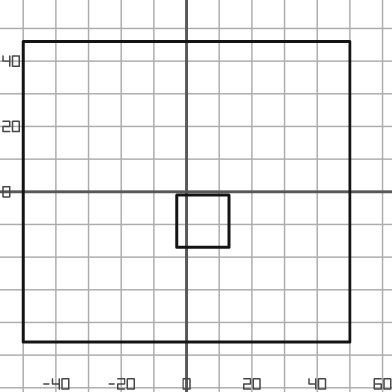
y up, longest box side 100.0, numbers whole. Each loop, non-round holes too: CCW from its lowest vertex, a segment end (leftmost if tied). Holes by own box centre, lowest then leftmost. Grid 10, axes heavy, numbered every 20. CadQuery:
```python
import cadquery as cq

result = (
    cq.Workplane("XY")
    .moveTo(-50.0, -46.0)
    .lineTo(50.0, -46.0)
    .lineTo(50.0, 46.0)
    .lineTo(-50.0, 46.0)
    .close()
    .moveTo(-3.0, -17.0)
    .lineTo(13.0, -17.0)
    .lineTo(13.0, -1.0)
    .lineTo(-3.0, -1.0)
    .close()
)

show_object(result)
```